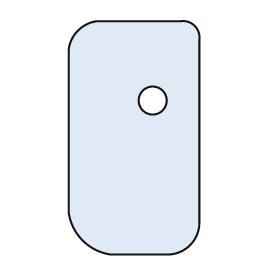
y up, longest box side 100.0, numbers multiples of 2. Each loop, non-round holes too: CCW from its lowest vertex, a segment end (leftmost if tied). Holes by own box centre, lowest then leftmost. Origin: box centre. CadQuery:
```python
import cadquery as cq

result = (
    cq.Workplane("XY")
    .moveTo(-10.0, -50.0)
    .lineTo(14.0, -50.0)
    .threePointArc((24.0, -46.0), (28.0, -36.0))
    .lineTo(28.0, 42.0)
    .threePointArc((26.0, 48.0), (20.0, 50.0))
    .lineTo(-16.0, 50.0)
    .threePointArc((-24.0, 46.0), (-28.0, 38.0))
    .lineTo(-28.0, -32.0)
    .threePointArc((-22.0, -44.0), (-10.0, -50.0))
    .close()
    .moveTo(8.0, 16.0)
    .circle(6.0)
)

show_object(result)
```